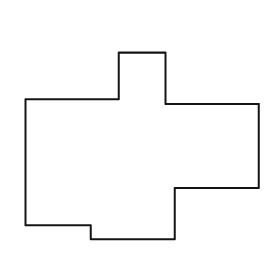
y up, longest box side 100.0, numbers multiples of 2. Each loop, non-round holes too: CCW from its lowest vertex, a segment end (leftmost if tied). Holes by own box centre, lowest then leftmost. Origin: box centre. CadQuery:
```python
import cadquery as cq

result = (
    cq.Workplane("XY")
    .moveTo(-22.0, -40.0)
    .lineTo(14.0, -40.0)
    .lineTo(14.0, -18.0)
    .lineTo(50.0, -18.0)
    .lineTo(50.0, 18.0)
    .lineTo(10.0, 18.0)
    .lineTo(10.0, 40.0)
    .lineTo(-10.0, 40.0)
    .lineTo(-10.0, 20.0)
    .lineTo(-50.0, 20.0)
    .lineTo(-50.0, -34.0)
    .lineTo(-22.0, -34.0)
    .close()
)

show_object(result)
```